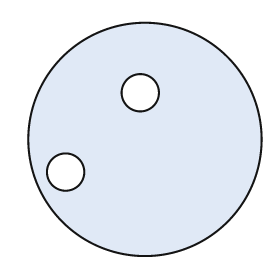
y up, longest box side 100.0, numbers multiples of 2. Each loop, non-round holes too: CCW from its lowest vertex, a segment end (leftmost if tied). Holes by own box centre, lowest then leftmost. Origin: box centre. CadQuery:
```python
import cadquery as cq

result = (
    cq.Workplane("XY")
    .moveTo(0.0, 0.0)
    .circle(50.0)
    .moveTo(-34.0, -14.0)
    .circle(8.0)
    .moveTo(-2.0, 20.0)
    .circle(8.0)
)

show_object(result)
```